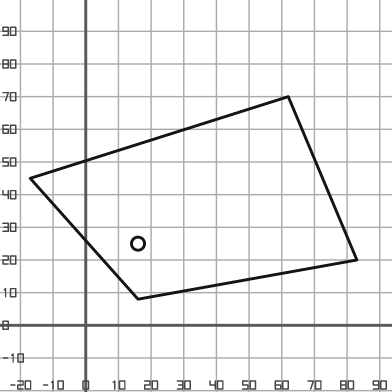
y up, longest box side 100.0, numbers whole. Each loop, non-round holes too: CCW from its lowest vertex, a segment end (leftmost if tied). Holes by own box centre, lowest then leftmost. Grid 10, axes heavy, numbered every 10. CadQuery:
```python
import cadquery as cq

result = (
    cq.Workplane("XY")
    .moveTo(16.0, 8.0)
    .lineTo(83.0, 20.0)
    .lineTo(62.0, 70.0)
    .lineTo(-17.0, 45.0)
    .close()
    .moveTo(16.0, 25.0)
    .circle(2.0)
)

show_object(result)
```